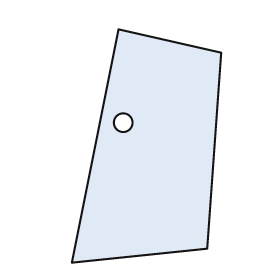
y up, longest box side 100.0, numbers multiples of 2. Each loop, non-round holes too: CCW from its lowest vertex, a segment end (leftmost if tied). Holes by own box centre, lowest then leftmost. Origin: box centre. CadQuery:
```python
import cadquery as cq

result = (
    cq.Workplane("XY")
    .moveTo(-32.0, -50.0)
    .lineTo(26.0, -44.0)
    .lineTo(32.0, 40.0)
    .lineTo(-12.0, 50.0)
    .close()
    .moveTo(-10.0, 10.0)
    .circle(4.0)
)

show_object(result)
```